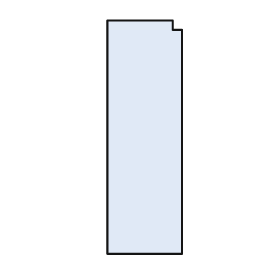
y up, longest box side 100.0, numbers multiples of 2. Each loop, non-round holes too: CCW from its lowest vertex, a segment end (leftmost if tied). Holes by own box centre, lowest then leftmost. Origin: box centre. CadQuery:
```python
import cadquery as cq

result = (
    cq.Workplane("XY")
    .moveTo(-16.0, -50.0)
    .lineTo(16.0, -50.0)
    .lineTo(16.0, 46.0)
    .lineTo(12.0, 46.0)
    .lineTo(12.0, 50.0)
    .lineTo(-16.0, 50.0)
    .close()
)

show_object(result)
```